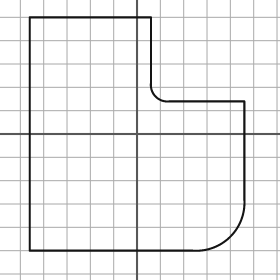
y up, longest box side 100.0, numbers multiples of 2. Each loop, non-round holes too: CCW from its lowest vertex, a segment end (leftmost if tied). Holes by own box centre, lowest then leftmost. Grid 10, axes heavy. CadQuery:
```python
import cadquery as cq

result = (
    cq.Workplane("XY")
    .moveTo(-46.0, -50.0)
    .lineTo(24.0, -50.0)
    .threePointArc((40.0, -44.0), (46.0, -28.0))
    .lineTo(46.0, 14.0)
    .lineTo(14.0, 14.0)
    .threePointArc((8.0, 16.0), (6.0, 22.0))
    .lineTo(6.0, 50.0)
    .lineTo(-46.0, 50.0)
    .close()
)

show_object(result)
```